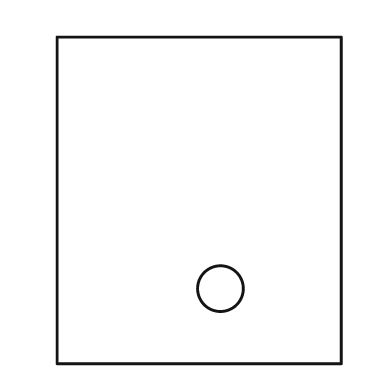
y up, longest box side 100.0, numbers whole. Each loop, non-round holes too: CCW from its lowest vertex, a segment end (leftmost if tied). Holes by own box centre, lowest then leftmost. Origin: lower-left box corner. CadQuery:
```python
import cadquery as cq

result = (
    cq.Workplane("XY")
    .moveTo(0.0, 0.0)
    .lineTo(87.0, 0.0)
    .lineTo(87.0, 100.0)
    .lineTo(0.0, 100.0)
    .close()
    .moveTo(50.0, 23.0)
    .circle(7.0)
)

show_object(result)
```